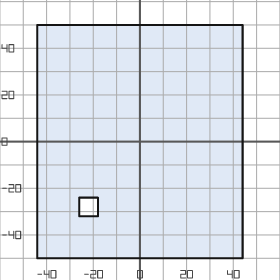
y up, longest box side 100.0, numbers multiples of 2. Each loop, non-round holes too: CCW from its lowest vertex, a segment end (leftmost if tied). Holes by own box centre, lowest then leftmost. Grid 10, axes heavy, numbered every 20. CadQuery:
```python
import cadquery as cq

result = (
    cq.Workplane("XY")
    .moveTo(-44.0, -50.0)
    .lineTo(44.0, -50.0)
    .lineTo(44.0, 50.0)
    .lineTo(-44.0, 50.0)
    .close()
    .moveTo(-26.0, -32.0)
    .lineTo(-18.0, -32.0)
    .lineTo(-18.0, -24.0)
    .lineTo(-26.0, -24.0)
    .close()
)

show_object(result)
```